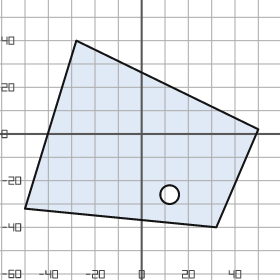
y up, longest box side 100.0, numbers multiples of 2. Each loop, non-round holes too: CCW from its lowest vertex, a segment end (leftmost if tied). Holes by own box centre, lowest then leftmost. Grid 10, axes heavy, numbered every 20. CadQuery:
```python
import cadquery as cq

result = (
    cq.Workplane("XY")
    .moveTo(32.0, -40.0)
    .lineTo(50.0, 2.0)
    .lineTo(-28.0, 40.0)
    .lineTo(-50.0, -32.0)
    .close()
    .moveTo(12.0, -26.0)
    .circle(4.0)
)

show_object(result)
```